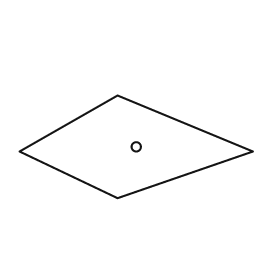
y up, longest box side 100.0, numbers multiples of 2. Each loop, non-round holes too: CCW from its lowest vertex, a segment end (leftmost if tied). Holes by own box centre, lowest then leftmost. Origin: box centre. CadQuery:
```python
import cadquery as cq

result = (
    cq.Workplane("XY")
    .moveTo(-8.0, -22.0)
    .lineTo(50.0, -2.0)
    .lineTo(-8.0, 22.0)
    .lineTo(-50.0, -2.0)
    .close()
    .moveTo(0.0, 0.0)
    .circle(2.0)
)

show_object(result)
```